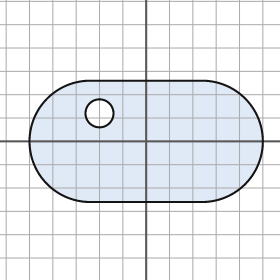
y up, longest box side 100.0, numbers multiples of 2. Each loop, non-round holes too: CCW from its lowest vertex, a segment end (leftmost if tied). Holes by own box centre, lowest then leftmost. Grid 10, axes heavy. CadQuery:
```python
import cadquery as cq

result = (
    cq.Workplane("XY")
    .moveTo(-24.0, -26.0)
    .lineTo(24.0, -26.0)
    .threePointArc((50.0, 0.0), (24.0, 26.0))
    .lineTo(-24.0, 26.0)
    .threePointArc((-50.0, 0.0), (-24.0, -26.0))
    .close()
    .moveTo(-20.0, 12.0)
    .circle(6.0)
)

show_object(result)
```